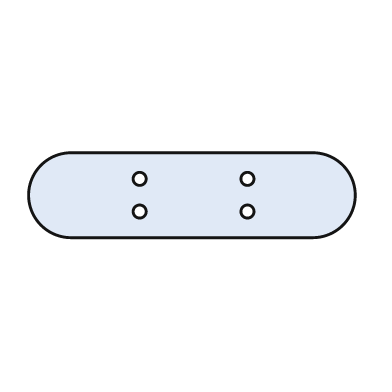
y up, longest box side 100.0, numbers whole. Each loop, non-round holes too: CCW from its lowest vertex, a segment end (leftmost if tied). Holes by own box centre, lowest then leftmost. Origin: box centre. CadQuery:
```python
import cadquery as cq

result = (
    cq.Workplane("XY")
    .moveTo(-37.0, -13.0)
    .lineTo(37.0, -13.0)
    .threePointArc((50.0, 0.0), (37.0, 13.0))
    .lineTo(-37.0, 13.0)
    .threePointArc((-50.0, 0.0), (-37.0, -13.0))
    .close()
    .moveTo(-16.0, -5.0)
    .circle(2.0)
    .moveTo(17.0, -5.0)
    .circle(2.0)
    .moveTo(-16.0, 5.0)
    .circle(2.0)
    .moveTo(17.0, 5.0)
    .circle(2.0)
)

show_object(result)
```